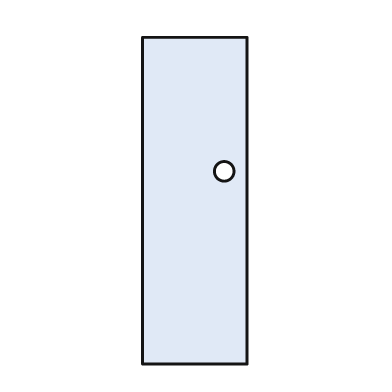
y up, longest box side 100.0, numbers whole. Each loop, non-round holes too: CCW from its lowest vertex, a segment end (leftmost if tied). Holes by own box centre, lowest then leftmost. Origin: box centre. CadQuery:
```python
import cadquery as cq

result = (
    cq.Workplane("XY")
    .moveTo(-16.0, -50.0)
    .lineTo(16.0, -50.0)
    .lineTo(16.0, 50.0)
    .lineTo(-16.0, 50.0)
    .close()
    .moveTo(9.0, 9.0)
    .circle(3.0)
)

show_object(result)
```